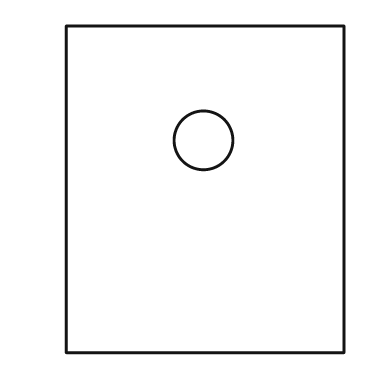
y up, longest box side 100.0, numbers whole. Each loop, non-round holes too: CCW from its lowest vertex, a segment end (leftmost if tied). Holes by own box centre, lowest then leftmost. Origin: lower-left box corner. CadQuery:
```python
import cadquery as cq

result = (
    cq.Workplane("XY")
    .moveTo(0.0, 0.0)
    .lineTo(85.0, 0.0)
    .lineTo(85.0, 100.0)
    .lineTo(0.0, 100.0)
    .close()
    .moveTo(42.0, 65.0)
    .circle(9.0)
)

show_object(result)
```